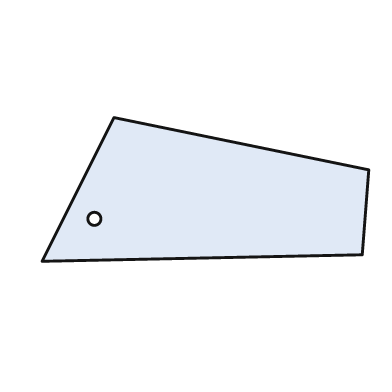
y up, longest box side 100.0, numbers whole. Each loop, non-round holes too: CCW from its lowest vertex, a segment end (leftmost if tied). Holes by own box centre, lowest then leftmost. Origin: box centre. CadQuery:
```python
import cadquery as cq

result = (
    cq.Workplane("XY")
    .moveTo(-50.0, -22.0)
    .lineTo(48.0, -20.0)
    .lineTo(50.0, 6.0)
    .lineTo(-28.0, 22.0)
    .close()
    .moveTo(-34.0, -9.0)
    .circle(2.0)
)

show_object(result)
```